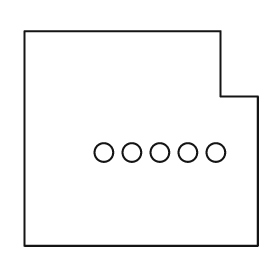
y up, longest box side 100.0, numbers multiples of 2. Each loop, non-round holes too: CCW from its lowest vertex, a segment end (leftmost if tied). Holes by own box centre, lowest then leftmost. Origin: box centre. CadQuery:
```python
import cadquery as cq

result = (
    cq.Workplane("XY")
    .moveTo(-50.0, -46.0)
    .lineTo(50.0, -46.0)
    .lineTo(50.0, 18.0)
    .lineTo(34.0, 18.0)
    .lineTo(34.0, 46.0)
    .lineTo(-50.0, 46.0)
    .close()
    .moveTo(-16.0, -6.0)
    .circle(4.0)
    .moveTo(-4.0, -6.0)
    .circle(4.0)
    .moveTo(8.0, -6.0)
    .circle(4.0)
    .moveTo(20.0, -6.0)
    .circle(4.0)
    .moveTo(32.0, -6.0)
    .circle(4.0)
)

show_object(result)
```